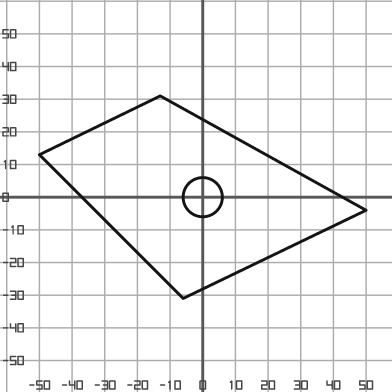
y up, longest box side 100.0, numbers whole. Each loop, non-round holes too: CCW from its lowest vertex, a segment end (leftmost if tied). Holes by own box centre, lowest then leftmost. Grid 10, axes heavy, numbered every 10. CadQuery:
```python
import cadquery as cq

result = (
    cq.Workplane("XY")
    .moveTo(-6.0, -31.0)
    .lineTo(50.0, -4.0)
    .lineTo(-13.0, 31.0)
    .lineTo(-50.0, 13.0)
    .close()
    .moveTo(0.0, 0.0)
    .circle(6.0)
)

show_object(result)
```